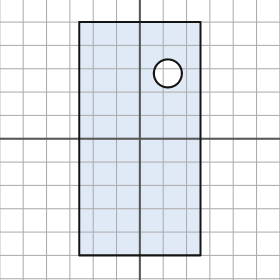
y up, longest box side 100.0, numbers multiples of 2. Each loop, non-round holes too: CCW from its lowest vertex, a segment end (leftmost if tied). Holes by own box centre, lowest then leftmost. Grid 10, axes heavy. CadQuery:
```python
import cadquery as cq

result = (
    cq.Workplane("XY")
    .moveTo(-26.0, -50.0)
    .lineTo(26.0, -50.0)
    .lineTo(26.0, 50.0)
    .lineTo(-26.0, 50.0)
    .close()
    .moveTo(12.0, 28.0)
    .circle(6.0)
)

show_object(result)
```